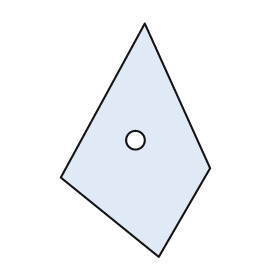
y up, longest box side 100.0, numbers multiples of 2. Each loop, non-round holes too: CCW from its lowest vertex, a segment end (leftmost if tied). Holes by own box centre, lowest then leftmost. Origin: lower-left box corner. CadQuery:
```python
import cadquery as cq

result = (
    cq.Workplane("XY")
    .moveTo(42.0, 0.0)
    .lineTo(64.0, 38.0)
    .lineTo(36.0, 100.0)
    .lineTo(0.0, 34.0)
    .close()
    .moveTo(32.0, 50.0)
    .circle(4.0)
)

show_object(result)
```